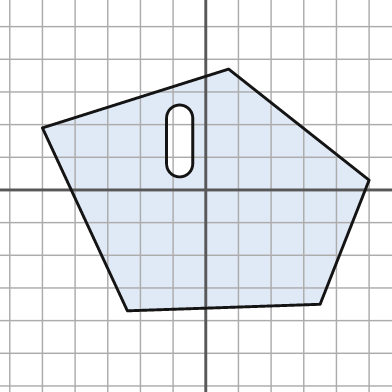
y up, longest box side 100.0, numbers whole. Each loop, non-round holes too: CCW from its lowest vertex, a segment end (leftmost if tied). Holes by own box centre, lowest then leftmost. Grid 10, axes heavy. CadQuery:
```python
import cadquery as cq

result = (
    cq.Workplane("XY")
    .moveTo(-24.0, -37.0)
    .lineTo(35.0, -35.0)
    .lineTo(50.0, 3.0)
    .lineTo(7.0, 37.0)
    .lineTo(-50.0, 19.0)
    .close()
    .moveTo(-12.0, 8.0)
    .threePointArc((-8.0, 4.0), (-4.0, 8.0))
    .lineTo(-4.0, 22.0)
    .threePointArc((-8.0, 26.0), (-12.0, 22.0))
    .close()
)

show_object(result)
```